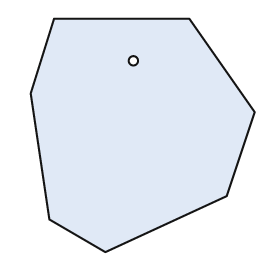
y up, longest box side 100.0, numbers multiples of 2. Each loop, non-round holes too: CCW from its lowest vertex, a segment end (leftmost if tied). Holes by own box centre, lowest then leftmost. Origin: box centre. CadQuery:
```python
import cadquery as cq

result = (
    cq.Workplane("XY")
    .moveTo(-16.0, -50.0)
    .lineTo(36.0, -26.0)
    .lineTo(48.0, 10.0)
    .lineTo(20.0, 50.0)
    .lineTo(-38.0, 50.0)
    .lineTo(-48.0, 18.0)
    .lineTo(-40.0, -36.0)
    .close()
    .moveTo(-4.0, 32.0)
    .circle(2.0)
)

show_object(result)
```